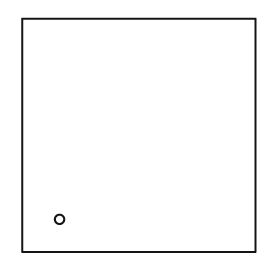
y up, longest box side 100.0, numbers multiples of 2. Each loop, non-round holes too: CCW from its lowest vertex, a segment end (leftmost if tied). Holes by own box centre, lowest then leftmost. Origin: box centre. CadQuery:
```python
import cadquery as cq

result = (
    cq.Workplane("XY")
    .moveTo(-50.0, -50.0)
    .lineTo(50.0, -50.0)
    .lineTo(50.0, 50.0)
    .lineTo(-50.0, 50.0)
    .close()
    .moveTo(-34.0, -36.0)
    .circle(2.0)
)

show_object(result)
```